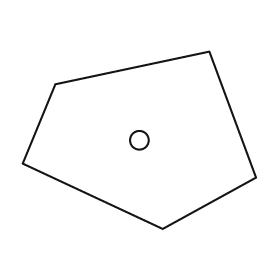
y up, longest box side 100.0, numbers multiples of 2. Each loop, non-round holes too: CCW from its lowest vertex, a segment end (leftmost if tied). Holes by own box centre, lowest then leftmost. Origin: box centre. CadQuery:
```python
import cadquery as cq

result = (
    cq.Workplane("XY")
    .moveTo(10.0, -38.0)
    .lineTo(50.0, -16.0)
    .lineTo(30.0, 38.0)
    .lineTo(-36.0, 24.0)
    .lineTo(-50.0, -10.0)
    .close()
    .moveTo(0.0, 0.0)
    .circle(4.0)
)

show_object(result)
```